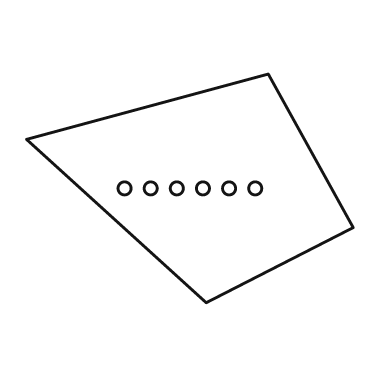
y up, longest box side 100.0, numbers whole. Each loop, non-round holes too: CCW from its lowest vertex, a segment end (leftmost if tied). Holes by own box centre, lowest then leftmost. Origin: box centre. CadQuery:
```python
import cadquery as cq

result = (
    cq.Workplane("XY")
    .moveTo(5.0, -35.0)
    .lineTo(50.0, -12.0)
    .lineTo(24.0, 35.0)
    .lineTo(-50.0, 15.0)
    .close()
    .moveTo(-20.0, 0.0)
    .circle(2.0)
    .moveTo(-12.0, 0.0)
    .circle(2.0)
    .moveTo(-4.0, 0.0)
    .circle(2.0)
    .moveTo(4.0, 0.0)
    .circle(2.0)
    .moveTo(12.0, 0.0)
    .circle(2.0)
    .moveTo(20.0, 0.0)
    .circle(2.0)
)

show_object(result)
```